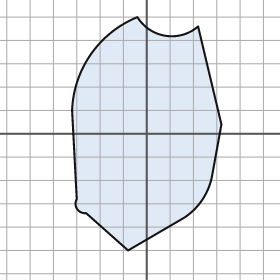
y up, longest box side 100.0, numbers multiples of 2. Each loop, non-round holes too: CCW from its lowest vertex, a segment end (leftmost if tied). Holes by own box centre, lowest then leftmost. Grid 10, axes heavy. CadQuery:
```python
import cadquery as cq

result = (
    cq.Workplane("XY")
    .moveTo(-8.0, -50.0)
    .lineTo(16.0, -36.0)
    .threePointArc((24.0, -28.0), (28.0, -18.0))
    .lineTo(32.0, 4.0)
    .lineTo(22.0, 46.0)
    .threePointArc((8.0, 42.0), (-4.0, 50.0))
    .threePointArc((-24.0, 34.0), (-32.0, 10.0))
    .lineTo(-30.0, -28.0)
    .threePointArc((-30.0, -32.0), (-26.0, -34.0))
    .close()
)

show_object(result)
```